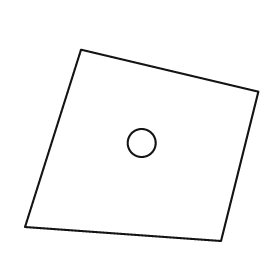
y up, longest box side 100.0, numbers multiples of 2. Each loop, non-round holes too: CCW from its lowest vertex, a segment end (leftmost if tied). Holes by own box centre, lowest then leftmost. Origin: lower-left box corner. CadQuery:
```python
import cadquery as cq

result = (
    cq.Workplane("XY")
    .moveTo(84.0, 0.0)
    .lineTo(100.0, 64.0)
    .lineTo(24.0, 82.0)
    .lineTo(0.0, 6.0)
    .close()
    .moveTo(50.0, 42.0)
    .circle(6.0)
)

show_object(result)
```